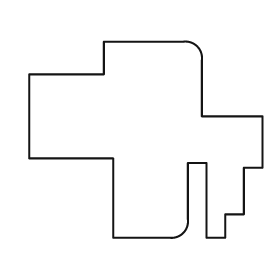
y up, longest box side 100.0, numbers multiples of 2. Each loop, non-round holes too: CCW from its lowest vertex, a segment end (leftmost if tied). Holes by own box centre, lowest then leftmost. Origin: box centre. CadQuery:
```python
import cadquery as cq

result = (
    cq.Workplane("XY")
    .moveTo(-14.0, -42.0)
    .lineTo(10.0, -42.0)
    .threePointArc((16.0, -40.0), (18.0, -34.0))
    .lineTo(18.0, -10.0)
    .lineTo(26.0, -10.0)
    .lineTo(26.0, -42.0)
    .lineTo(34.0, -42.0)
    .lineTo(34.0, -32.0)
    .lineTo(42.0, -32.0)
    .lineTo(42.0, -12.0)
    .lineTo(50.0, -12.0)
    .lineTo(50.0, 10.0)
    .lineTo(24.0, 10.0)
    .lineTo(24.0, 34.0)
    .threePointArc((22.0, 40.0), (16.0, 42.0))
    .lineTo(-18.0, 42.0)
    .lineTo(-18.0, 28.0)
    .lineTo(-50.0, 28.0)
    .lineTo(-50.0, -8.0)
    .lineTo(-14.0, -8.0)
    .close()
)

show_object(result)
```